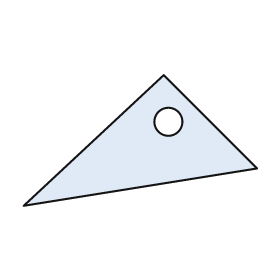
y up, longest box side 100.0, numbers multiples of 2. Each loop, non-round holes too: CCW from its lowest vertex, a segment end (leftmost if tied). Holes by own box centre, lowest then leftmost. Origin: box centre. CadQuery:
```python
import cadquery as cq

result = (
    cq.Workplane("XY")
    .moveTo(-50.0, -28.0)
    .lineTo(50.0, -12.0)
    .lineTo(10.0, 28.0)
    .close()
    .moveTo(12.0, 8.0)
    .circle(6.0)
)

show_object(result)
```